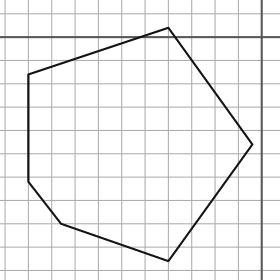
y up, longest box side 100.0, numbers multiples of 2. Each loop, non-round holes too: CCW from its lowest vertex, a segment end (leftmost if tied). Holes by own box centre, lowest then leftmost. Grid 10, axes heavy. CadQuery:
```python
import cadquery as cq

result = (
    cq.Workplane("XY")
    .moveTo(-40.0, -96.0)
    .lineTo(-4.0, -46.0)
    .lineTo(-40.0, 4.0)
    .lineTo(-100.0, -16.0)
    .lineTo(-100.0, -62.0)
    .lineTo(-86.0, -80.0)
    .close()
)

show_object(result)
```